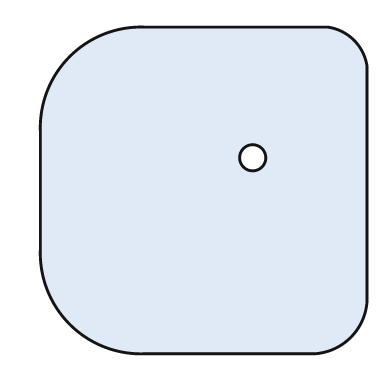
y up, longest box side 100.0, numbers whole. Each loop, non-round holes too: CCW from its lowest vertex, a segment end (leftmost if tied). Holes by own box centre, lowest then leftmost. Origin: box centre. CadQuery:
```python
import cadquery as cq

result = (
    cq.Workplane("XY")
    .moveTo(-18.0, -50.0)
    .lineTo(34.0, -50.0)
    .threePointArc((45.0, -45.0), (50.0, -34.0))
    .lineTo(50.0, 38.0)
    .threePointArc((46.0, 46.0), (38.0, 50.0))
    .lineTo(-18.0, 50.0)
    .threePointArc((-41.0, 41.0), (-50.0, 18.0))
    .lineTo(-50.0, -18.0)
    .threePointArc((-41.0, -41.0), (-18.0, -50.0))
    .close()
    .moveTo(15.0, 10.0)
    .circle(4.0)
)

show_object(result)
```